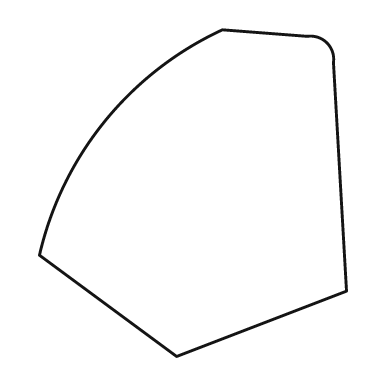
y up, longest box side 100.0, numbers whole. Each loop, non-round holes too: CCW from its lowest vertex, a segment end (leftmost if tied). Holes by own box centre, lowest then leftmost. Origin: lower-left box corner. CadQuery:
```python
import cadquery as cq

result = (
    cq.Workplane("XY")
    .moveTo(42.0, 0.0)
    .lineTo(94.0, 20.0)
    .lineTo(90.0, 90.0)
    .threePointArc((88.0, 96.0), (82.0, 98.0))
    .lineTo(56.0, 100.0)
    .threePointArc((20.0, 72.0), (0.0, 31.0))
    .close()
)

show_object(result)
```